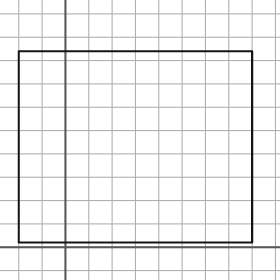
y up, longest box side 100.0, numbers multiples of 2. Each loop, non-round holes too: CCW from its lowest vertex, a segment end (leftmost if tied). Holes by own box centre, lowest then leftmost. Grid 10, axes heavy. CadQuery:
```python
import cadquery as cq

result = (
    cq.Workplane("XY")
    .moveTo(-20.0, 2.0)
    .lineTo(80.0, 2.0)
    .lineTo(80.0, 84.0)
    .lineTo(-20.0, 84.0)
    .close()
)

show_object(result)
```